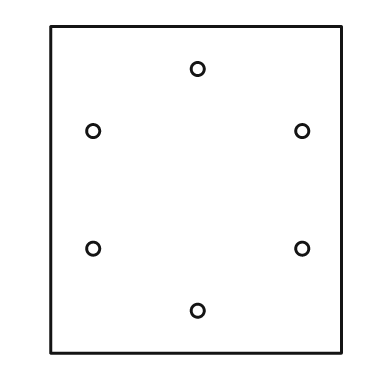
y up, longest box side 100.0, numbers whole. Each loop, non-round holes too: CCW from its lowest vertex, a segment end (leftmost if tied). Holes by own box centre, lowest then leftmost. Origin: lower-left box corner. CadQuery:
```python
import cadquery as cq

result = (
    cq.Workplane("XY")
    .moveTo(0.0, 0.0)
    .lineTo(89.0, 0.0)
    .lineTo(89.0, 100.0)
    .lineTo(0.0, 100.0)
    .close()
    .moveTo(45.0, 13.0)
    .circle(2.0)
    .moveTo(13.0, 32.0)
    .circle(2.0)
    .moveTo(77.0, 32.0)
    .circle(2.0)
    .moveTo(13.0, 68.0)
    .circle(2.0)
    .moveTo(77.0, 68.0)
    .circle(2.0)
    .moveTo(45.0, 87.0)
    .circle(2.0)
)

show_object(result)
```